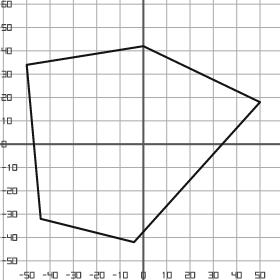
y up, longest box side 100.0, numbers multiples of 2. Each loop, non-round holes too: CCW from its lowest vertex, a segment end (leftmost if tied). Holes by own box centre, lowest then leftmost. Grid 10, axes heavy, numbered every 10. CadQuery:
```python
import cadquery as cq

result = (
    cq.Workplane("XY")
    .moveTo(-4.0, -42.0)
    .lineTo(50.0, 18.0)
    .lineTo(0.0, 42.0)
    .lineTo(-50.0, 34.0)
    .lineTo(-44.0, -32.0)
    .close()
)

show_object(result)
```